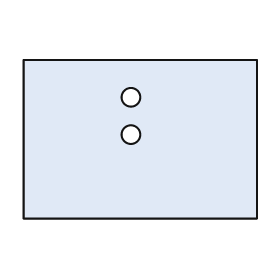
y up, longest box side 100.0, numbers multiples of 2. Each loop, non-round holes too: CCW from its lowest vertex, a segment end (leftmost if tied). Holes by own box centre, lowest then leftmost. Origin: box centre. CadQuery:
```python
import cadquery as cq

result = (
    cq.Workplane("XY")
    .moveTo(-50.0, -34.0)
    .lineTo(50.0, -34.0)
    .lineTo(50.0, 34.0)
    .lineTo(-50.0, 34.0)
    .close()
    .moveTo(-4.0, 2.0)
    .circle(4.0)
    .moveTo(-4.0, 18.0)
    .circle(4.0)
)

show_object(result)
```